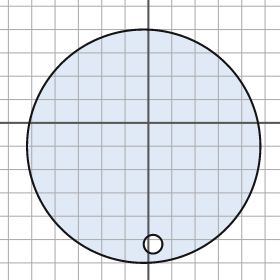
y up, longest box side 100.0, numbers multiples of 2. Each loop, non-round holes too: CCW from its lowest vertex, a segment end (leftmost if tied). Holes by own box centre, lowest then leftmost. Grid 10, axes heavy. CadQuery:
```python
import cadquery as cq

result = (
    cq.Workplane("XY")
    .moveTo(-2.0, -10.0)
    .circle(50.0)
    .moveTo(2.0, -52.0)
    .circle(4.0)
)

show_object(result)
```